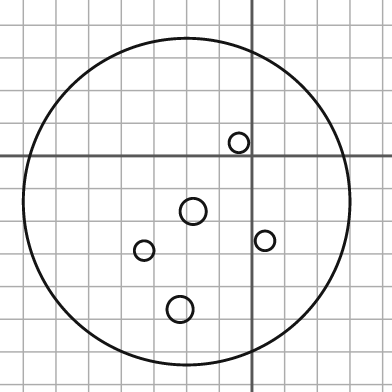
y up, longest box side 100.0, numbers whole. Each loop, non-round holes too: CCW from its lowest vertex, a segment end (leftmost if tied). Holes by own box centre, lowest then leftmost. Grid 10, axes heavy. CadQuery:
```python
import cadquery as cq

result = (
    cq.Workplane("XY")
    .moveTo(-20.0, -14.0)
    .circle(50.0)
    .moveTo(-22.0, -47.0)
    .circle(4.0)
    .moveTo(-33.0, -29.0)
    .circle(3.0)
    .moveTo(4.0, -26.0)
    .circle(3.0)
    .moveTo(-18.0, -17.0)
    .circle(4.0)
    .moveTo(-4.0, 4.0)
    .circle(3.0)
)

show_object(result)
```